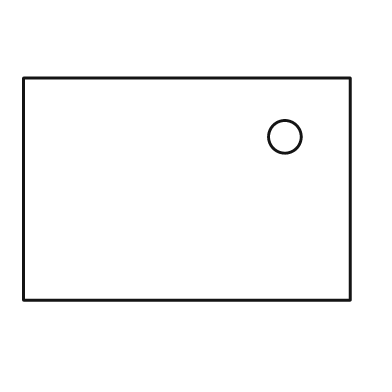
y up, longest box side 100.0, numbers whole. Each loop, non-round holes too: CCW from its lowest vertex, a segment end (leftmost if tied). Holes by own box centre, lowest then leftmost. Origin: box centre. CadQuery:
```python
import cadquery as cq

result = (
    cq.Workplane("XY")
    .moveTo(-50.0, -34.0)
    .lineTo(50.0, -34.0)
    .lineTo(50.0, 34.0)
    .lineTo(-50.0, 34.0)
    .close()
    .moveTo(30.0, 16.0)
    .circle(5.0)
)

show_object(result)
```